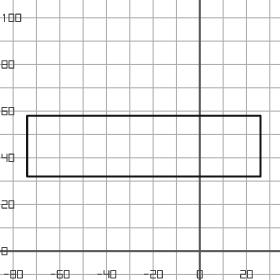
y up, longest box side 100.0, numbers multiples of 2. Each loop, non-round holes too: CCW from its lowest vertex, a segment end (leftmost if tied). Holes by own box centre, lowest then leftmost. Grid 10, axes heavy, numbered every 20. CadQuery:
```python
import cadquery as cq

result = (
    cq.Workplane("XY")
    .moveTo(-74.0, 32.0)
    .lineTo(26.0, 32.0)
    .lineTo(26.0, 58.0)
    .lineTo(-74.0, 58.0)
    .close()
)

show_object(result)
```